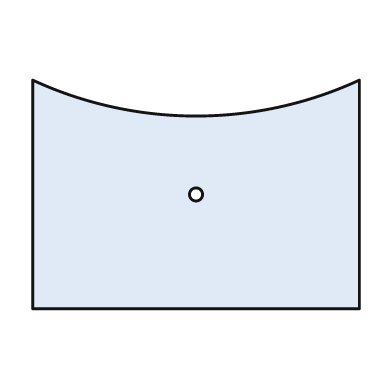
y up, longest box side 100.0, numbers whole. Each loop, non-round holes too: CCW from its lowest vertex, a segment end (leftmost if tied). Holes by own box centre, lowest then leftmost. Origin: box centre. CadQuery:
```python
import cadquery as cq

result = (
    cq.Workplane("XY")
    .moveTo(-50.0, -35.0)
    .lineTo(50.0, -35.0)
    .lineTo(50.0, 35.0)
    .threePointArc((0.0, 24.0), (-50.0, 35.0))
    .close()
    .moveTo(0.0, 0.0)
    .circle(2.0)
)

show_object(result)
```